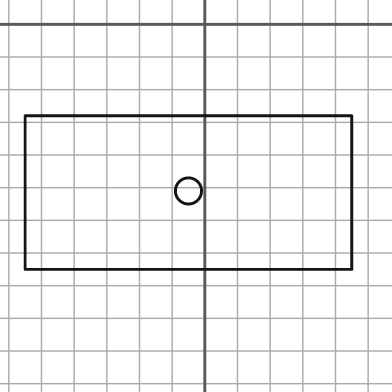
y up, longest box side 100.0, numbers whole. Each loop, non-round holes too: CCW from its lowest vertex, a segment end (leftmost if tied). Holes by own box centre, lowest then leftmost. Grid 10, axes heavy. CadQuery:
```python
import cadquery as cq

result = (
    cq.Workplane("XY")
    .moveTo(-55.0, -75.0)
    .lineTo(45.0, -75.0)
    .lineTo(45.0, -28.0)
    .lineTo(-55.0, -28.0)
    .close()
    .moveTo(-5.0, -51.0)
    .circle(4.0)
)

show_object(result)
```